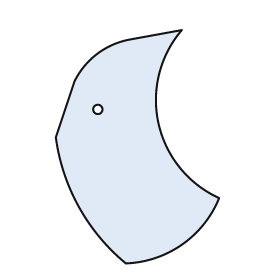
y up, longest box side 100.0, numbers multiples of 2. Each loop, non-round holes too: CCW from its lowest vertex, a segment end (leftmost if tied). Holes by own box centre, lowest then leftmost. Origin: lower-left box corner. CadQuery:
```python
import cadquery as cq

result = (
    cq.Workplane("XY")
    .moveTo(30.0, 0.0)
    .threePointArc((54.0, 8.0), (70.0, 28.0))
    .threePointArc((44.0, 60.0), (54.0, 100.0))
    .lineTo(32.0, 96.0)
    .threePointArc((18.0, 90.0), (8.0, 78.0))
    .lineTo(0.0, 54.0)
    .threePointArc((10.0, 24.0), (30.0, 0.0))
    .close()
    .moveTo(18.0, 66.0)
    .circle(2.0)
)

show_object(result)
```